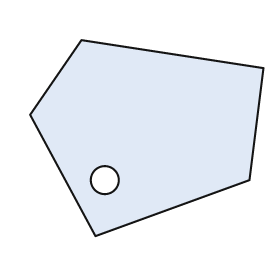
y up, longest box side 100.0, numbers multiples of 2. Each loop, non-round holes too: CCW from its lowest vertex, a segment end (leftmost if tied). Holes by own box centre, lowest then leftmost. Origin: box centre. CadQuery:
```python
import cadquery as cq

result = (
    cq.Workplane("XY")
    .moveTo(-22.0, -42.0)
    .lineTo(44.0, -18.0)
    .lineTo(50.0, 30.0)
    .lineTo(-28.0, 42.0)
    .lineTo(-50.0, 10.0)
    .close()
    .moveTo(-18.0, -18.0)
    .circle(6.0)
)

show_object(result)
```